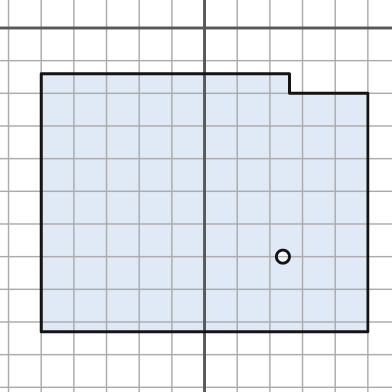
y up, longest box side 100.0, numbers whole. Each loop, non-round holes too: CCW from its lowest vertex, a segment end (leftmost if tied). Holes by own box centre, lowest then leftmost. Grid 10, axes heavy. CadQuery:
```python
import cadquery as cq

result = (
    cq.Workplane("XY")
    .moveTo(-50.0, -93.0)
    .lineTo(50.0, -93.0)
    .lineTo(50.0, -20.0)
    .lineTo(26.0, -20.0)
    .lineTo(26.0, -14.0)
    .lineTo(-50.0, -14.0)
    .close()
    .moveTo(24.0, -70.0)
    .circle(2.0)
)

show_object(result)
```